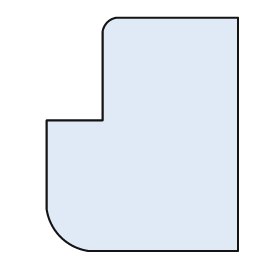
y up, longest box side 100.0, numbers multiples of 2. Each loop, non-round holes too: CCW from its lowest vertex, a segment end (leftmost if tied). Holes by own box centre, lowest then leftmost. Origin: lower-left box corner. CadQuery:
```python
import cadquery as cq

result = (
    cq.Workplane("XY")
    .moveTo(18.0, 0.0)
    .lineTo(82.0, 0.0)
    .lineTo(82.0, 100.0)
    .lineTo(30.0, 100.0)
    .threePointArc((26.0, 98.0), (24.0, 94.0))
    .lineTo(24.0, 56.0)
    .lineTo(0.0, 56.0)
    .lineTo(0.0, 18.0)
    .threePointArc((6.0, 6.0), (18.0, 0.0))
    .close()
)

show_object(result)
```